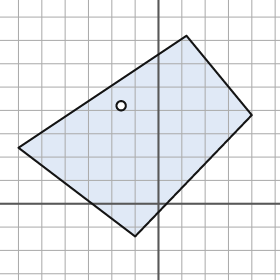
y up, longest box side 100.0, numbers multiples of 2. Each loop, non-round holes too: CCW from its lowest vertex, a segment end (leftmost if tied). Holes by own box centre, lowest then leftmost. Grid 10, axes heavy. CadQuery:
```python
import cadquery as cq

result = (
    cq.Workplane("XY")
    .moveTo(-10.0, -14.0)
    .lineTo(40.0, 38.0)
    .lineTo(12.0, 72.0)
    .lineTo(-60.0, 24.0)
    .close()
    .moveTo(-16.0, 42.0)
    .circle(2.0)
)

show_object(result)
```